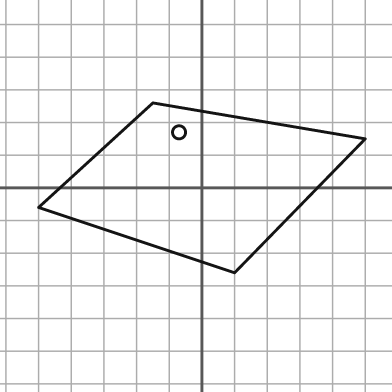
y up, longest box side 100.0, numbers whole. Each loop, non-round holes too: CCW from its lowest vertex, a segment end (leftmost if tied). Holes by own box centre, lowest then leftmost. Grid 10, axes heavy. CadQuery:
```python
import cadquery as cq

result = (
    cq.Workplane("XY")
    .moveTo(10.0, -26.0)
    .lineTo(50.0, 15.0)
    .lineTo(-15.0, 26.0)
    .lineTo(-50.0, -6.0)
    .close()
    .moveTo(-7.0, 17.0)
    .circle(2.0)
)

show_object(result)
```